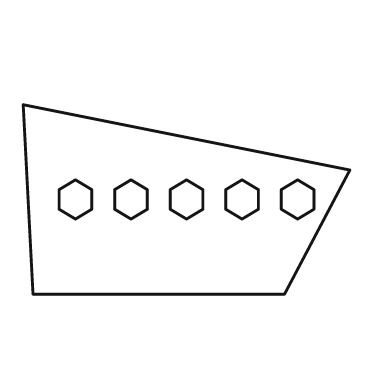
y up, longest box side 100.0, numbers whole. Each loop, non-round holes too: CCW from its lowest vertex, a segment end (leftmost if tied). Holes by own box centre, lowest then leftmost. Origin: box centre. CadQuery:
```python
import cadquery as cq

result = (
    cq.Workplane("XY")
    .moveTo(-47.0, -29.0)
    .lineTo(30.0, -29.0)
    .lineTo(50.0, 9.0)
    .lineTo(-50.0, 29.0)
    .close()
    .moveTo(-34.0, -6.0)
    .lineTo(-29.0, -3.0)
    .lineTo(-29.0, 3.0)
    .lineTo(-34.0, 6.0)
    .lineTo(-39.0, 3.0)
    .lineTo(-39.0, -3.0)
    .close()
    .moveTo(-17.0, -6.0)
    .lineTo(-12.0, -3.0)
    .lineTo(-12.0, 3.0)
    .lineTo(-17.0, 6.0)
    .lineTo(-22.0, 3.0)
    .lineTo(-22.0, -3.0)
    .close()
    .moveTo(0.0, -6.0)
    .lineTo(5.0, -3.0)
    .lineTo(5.0, 3.0)
    .lineTo(0.0, 6.0)
    .lineTo(-5.0, 3.0)
    .lineTo(-5.0, -3.0)
    .close()
    .moveTo(17.0, -6.0)
    .lineTo(22.0, -3.0)
    .lineTo(22.0, 3.0)
    .lineTo(17.0, 6.0)
    .lineTo(12.0, 3.0)
    .lineTo(12.0, -3.0)
    .close()
    .moveTo(34.0, -6.0)
    .lineTo(39.0, -3.0)
    .lineTo(39.0, 3.0)
    .lineTo(34.0, 6.0)
    .lineTo(29.0, 3.0)
    .lineTo(29.0, -3.0)
    .close()
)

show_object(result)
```